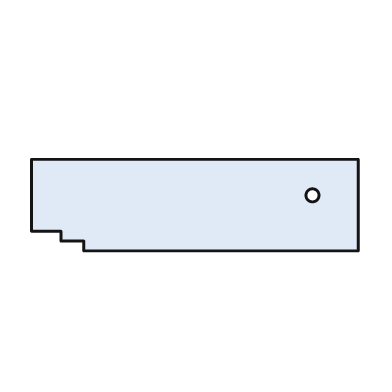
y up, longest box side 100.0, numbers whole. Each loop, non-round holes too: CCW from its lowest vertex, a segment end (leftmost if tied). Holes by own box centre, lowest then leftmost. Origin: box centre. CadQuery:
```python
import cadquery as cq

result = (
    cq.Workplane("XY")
    .moveTo(-34.0, -14.0)
    .lineTo(50.0, -14.0)
    .lineTo(50.0, 14.0)
    .lineTo(-50.0, 14.0)
    .lineTo(-50.0, -8.0)
    .lineTo(-41.0, -8.0)
    .lineTo(-41.0, -11.0)
    .lineTo(-34.0, -11.0)
    .close()
    .moveTo(36.0, 3.0)
    .circle(2.0)
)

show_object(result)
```